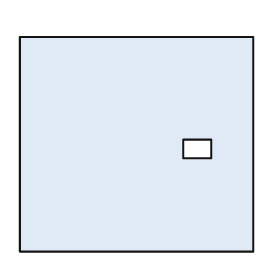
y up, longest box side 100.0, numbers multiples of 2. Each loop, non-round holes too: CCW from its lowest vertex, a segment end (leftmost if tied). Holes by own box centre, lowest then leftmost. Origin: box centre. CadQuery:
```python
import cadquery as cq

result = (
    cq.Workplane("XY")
    .moveTo(-50.0, -46.0)
    .lineTo(50.0, -46.0)
    .lineTo(50.0, 46.0)
    .lineTo(-50.0, 46.0)
    .close()
    .moveTo(20.0, -6.0)
    .lineTo(32.0, -6.0)
    .lineTo(32.0, 2.0)
    .lineTo(20.0, 2.0)
    .close()
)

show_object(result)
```